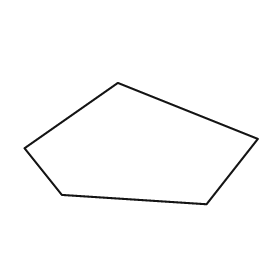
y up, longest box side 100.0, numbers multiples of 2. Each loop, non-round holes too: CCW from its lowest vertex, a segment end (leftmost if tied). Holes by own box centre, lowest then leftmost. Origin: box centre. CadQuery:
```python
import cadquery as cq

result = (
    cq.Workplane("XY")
    .moveTo(28.0, -26.0)
    .lineTo(50.0, 2.0)
    .lineTo(-10.0, 26.0)
    .lineTo(-50.0, -2.0)
    .lineTo(-34.0, -22.0)
    .close()
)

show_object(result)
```